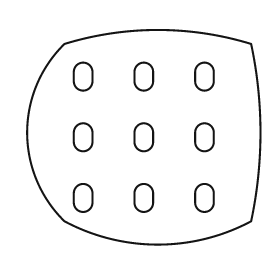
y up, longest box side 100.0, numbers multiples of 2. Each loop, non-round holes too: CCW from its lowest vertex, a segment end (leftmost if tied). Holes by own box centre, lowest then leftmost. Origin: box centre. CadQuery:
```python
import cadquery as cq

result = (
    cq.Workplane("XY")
    .moveTo(-34.0, -36.0)
    .threePointArc((6.0, -46.0), (46.0, -36.0))
    .threePointArc((50.0, 2.0), (46.0, 40.0))
    .threePointArc((6.0, 46.0), (-34.0, 40.0))
    .threePointArc((-50.0, 2.0), (-34.0, -36.0))
    .close()
    .moveTo(-30.0, -28.0)
    .threePointArc((-26.0, -32.0), (-22.0, -28.0))
    .lineTo(-22.0, -24.0)
    .threePointArc((-26.0, -20.0), (-30.0, -24.0))
    .close()
    .moveTo(-4.0, -28.0)
    .threePointArc((0.0, -32.0), (4.0, -28.0))
    .lineTo(4.0, -24.0)
    .threePointArc((0.0, -20.0), (-4.0, -24.0))
    .close()
    .moveTo(22.0, -28.0)
    .threePointArc((26.0, -32.0), (30.0, -28.0))
    .lineTo(30.0, -24.0)
    .threePointArc((26.0, -20.0), (22.0, -24.0))
    .close()
    .moveTo(-30.0, -2.0)
    .threePointArc((-26.0, -6.0), (-22.0, -2.0))
    .lineTo(-22.0, 2.0)
    .threePointArc((-26.0, 6.0), (-30.0, 2.0))
    .close()
    .moveTo(-4.0, -2.0)
    .threePointArc((0.0, -6.0), (4.0, -2.0))
    .lineTo(4.0, 2.0)
    .threePointArc((0.0, 6.0), (-4.0, 2.0))
    .close()
    .moveTo(22.0, -2.0)
    .threePointArc((26.0, -6.0), (30.0, -2.0))
    .lineTo(30.0, 2.0)
    .threePointArc((26.0, 6.0), (22.0, 2.0))
    .close()
    .moveTo(-30.0, 24.0)
    .threePointArc((-26.0, 20.0), (-22.0, 24.0))
    .lineTo(-22.0, 28.0)
    .threePointArc((-26.0, 32.0), (-30.0, 28.0))
    .close()
    .moveTo(-4.0, 24.0)
    .threePointArc((0.0, 20.0), (4.0, 24.0))
    .lineTo(4.0, 28.0)
    .threePointArc((0.0, 32.0), (-4.0, 28.0))
    .close()
    .moveTo(22.0, 24.0)
    .threePointArc((26.0, 20.0), (30.0, 24.0))
    .lineTo(30.0, 28.0)
    .threePointArc((26.0, 32.0), (22.0, 28.0))
    .close()
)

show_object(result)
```